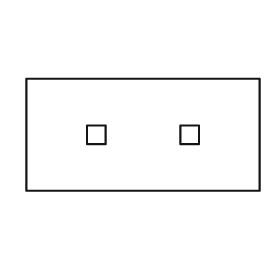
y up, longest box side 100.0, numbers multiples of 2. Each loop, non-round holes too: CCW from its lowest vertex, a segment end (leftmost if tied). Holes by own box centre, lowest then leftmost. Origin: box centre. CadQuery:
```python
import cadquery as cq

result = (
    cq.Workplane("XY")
    .moveTo(-50.0, -24.0)
    .lineTo(50.0, -24.0)
    .lineTo(50.0, 24.0)
    .lineTo(-50.0, 24.0)
    .close()
    .moveTo(-24.0, -4.0)
    .lineTo(-16.0, -4.0)
    .lineTo(-16.0, 4.0)
    .lineTo(-24.0, 4.0)
    .close()
    .moveTo(16.0, -4.0)
    .lineTo(24.0, -4.0)
    .lineTo(24.0, 4.0)
    .lineTo(16.0, 4.0)
    .close()
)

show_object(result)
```